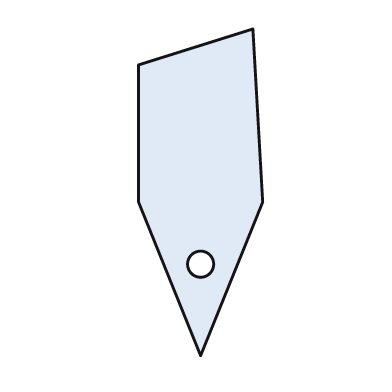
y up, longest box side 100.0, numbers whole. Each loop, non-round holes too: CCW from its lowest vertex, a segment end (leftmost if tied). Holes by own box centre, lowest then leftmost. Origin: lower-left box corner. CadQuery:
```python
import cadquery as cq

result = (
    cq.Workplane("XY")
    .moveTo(19.0, 0.0)
    .lineTo(38.0, 47.0)
    .lineTo(35.0, 100.0)
    .lineTo(0.0, 89.0)
    .lineTo(0.0, 47.0)
    .close()
    .moveTo(19.0, 28.0)
    .circle(4.0)
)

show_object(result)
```